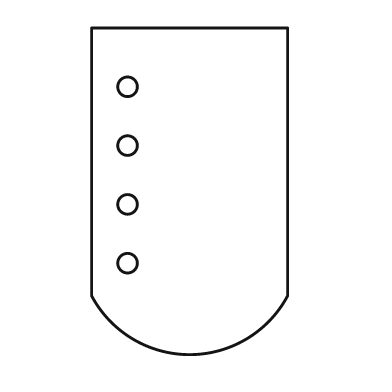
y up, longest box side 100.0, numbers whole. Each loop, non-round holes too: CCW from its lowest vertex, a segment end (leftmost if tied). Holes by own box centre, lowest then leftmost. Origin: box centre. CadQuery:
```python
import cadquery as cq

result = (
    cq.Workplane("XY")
    .moveTo(-30.0, -32.0)
    .threePointArc((0.0, -50.0), (30.0, -32.0))
    .lineTo(30.0, 50.0)
    .lineTo(-30.0, 50.0)
    .close()
    .moveTo(-19.0, -22.0)
    .circle(3.0)
    .moveTo(-19.0, -4.0)
    .circle(3.0)
    .moveTo(-19.0, 14.0)
    .circle(3.0)
    .moveTo(-19.0, 32.0)
    .circle(3.0)
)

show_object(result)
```